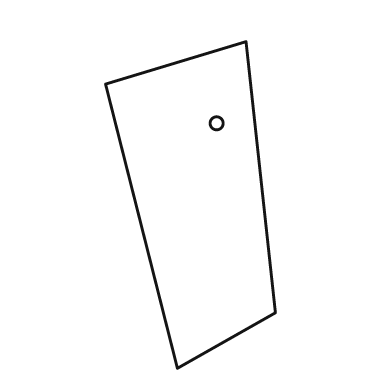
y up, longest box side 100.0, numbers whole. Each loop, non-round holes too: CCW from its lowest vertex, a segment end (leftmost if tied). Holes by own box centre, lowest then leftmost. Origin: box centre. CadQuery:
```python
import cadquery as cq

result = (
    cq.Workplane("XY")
    .moveTo(-4.0, -50.0)
    .lineTo(26.0, -33.0)
    .lineTo(17.0, 50.0)
    .lineTo(-26.0, 37.0)
    .close()
    .moveTo(8.0, 25.0)
    .circle(2.0)
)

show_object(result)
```